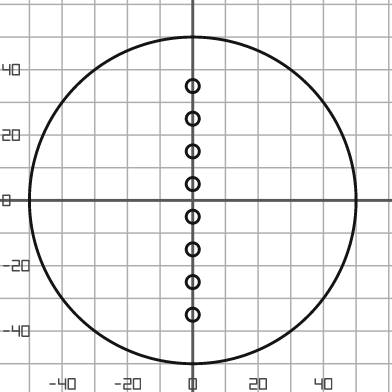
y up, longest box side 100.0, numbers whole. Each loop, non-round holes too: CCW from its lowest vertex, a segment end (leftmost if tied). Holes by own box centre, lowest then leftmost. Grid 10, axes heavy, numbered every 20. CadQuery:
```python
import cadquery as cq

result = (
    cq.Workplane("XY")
    .moveTo(0.0, 0.0)
    .circle(50.0)
    .moveTo(0.0, -35.0)
    .circle(2.0)
    .moveTo(0.0, -25.0)
    .circle(2.0)
    .moveTo(0.0, -15.0)
    .circle(2.0)
    .moveTo(0.0, -5.0)
    .circle(2.0)
    .moveTo(0.0, 5.0)
    .circle(2.0)
    .moveTo(0.0, 15.0)
    .circle(2.0)
    .moveTo(0.0, 25.0)
    .circle(2.0)
    .moveTo(0.0, 35.0)
    .circle(2.0)
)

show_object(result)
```